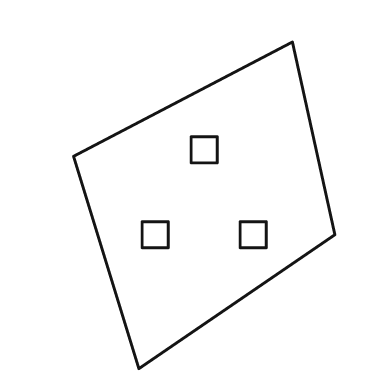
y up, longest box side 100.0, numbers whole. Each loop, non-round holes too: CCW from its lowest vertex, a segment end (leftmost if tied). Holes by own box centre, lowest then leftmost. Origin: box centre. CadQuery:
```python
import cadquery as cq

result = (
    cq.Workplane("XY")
    .moveTo(-20.0, -50.0)
    .lineTo(40.0, -9.0)
    .lineTo(27.0, 50.0)
    .lineTo(-40.0, 15.0)
    .close()
    .moveTo(-19.0, -13.0)
    .lineTo(-11.0, -13.0)
    .lineTo(-11.0, -5.0)
    .lineTo(-19.0, -5.0)
    .close()
    .moveTo(11.0, -13.0)
    .lineTo(19.0, -13.0)
    .lineTo(19.0, -5.0)
    .lineTo(11.0, -5.0)
    .close()
    .moveTo(-4.0, 13.0)
    .lineTo(4.0, 13.0)
    .lineTo(4.0, 21.0)
    .lineTo(-4.0, 21.0)
    .close()
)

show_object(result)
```